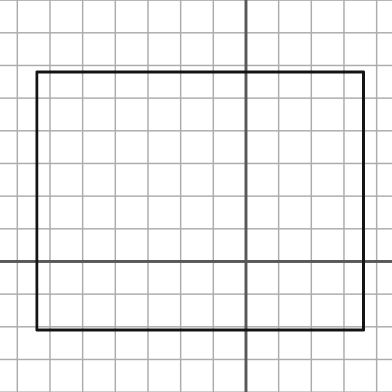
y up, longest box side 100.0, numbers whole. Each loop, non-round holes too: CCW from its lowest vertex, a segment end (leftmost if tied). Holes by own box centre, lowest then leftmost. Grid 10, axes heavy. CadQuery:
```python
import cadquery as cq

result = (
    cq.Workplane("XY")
    .moveTo(-64.0, -21.0)
    .lineTo(36.0, -21.0)
    .lineTo(36.0, 58.0)
    .lineTo(-64.0, 58.0)
    .close()
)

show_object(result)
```